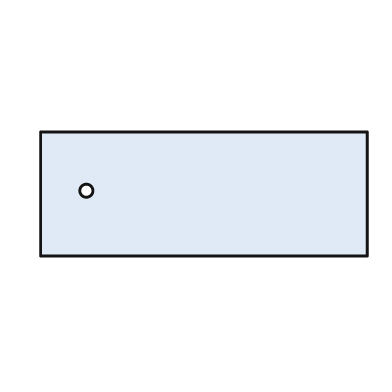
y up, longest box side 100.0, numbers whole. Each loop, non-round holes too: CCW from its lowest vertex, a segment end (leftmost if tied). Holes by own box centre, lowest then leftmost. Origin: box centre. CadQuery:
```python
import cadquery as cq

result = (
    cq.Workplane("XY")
    .moveTo(-50.0, -19.0)
    .lineTo(50.0, -19.0)
    .lineTo(50.0, 19.0)
    .lineTo(-50.0, 19.0)
    .close()
    .moveTo(-36.0, 1.0)
    .circle(2.0)
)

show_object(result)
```